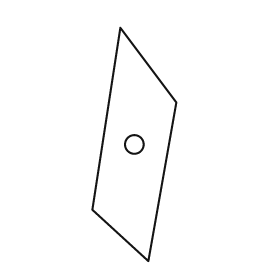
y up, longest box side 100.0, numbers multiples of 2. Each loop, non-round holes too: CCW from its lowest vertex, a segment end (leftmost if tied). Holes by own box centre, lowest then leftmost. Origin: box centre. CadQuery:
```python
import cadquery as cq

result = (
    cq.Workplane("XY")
    .moveTo(6.0, -50.0)
    .lineTo(18.0, 18.0)
    .lineTo(-6.0, 50.0)
    .lineTo(-18.0, -28.0)
    .close()
    .moveTo(0.0, 0.0)
    .circle(4.0)
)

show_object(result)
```